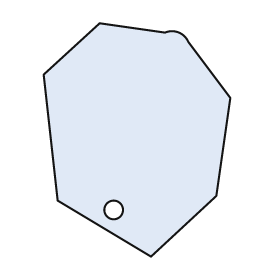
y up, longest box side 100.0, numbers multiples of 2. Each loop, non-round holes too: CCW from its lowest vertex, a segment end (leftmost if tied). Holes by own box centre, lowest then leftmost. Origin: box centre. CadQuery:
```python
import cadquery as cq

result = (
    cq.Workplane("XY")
    .moveTo(6.0, -50.0)
    .lineTo(34.0, -24.0)
    .lineTo(40.0, 18.0)
    .lineTo(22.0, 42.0)
    .threePointArc((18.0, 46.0), (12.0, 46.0))
    .lineTo(-16.0, 50.0)
    .lineTo(-40.0, 28.0)
    .lineTo(-34.0, -26.0)
    .close()
    .moveTo(-10.0, -30.0)
    .circle(4.0)
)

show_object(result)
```